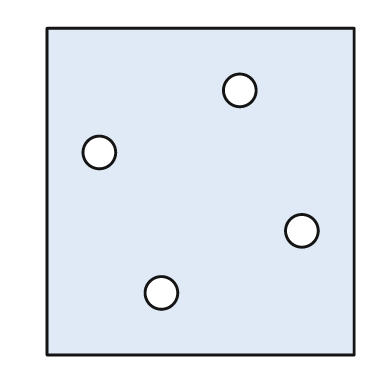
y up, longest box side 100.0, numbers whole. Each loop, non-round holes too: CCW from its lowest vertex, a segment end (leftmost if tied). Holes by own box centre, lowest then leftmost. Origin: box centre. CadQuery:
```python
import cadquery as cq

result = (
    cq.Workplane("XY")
    .moveTo(-47.0, -50.0)
    .lineTo(47.0, -50.0)
    .lineTo(47.0, 50.0)
    .lineTo(-47.0, 50.0)
    .close()
    .moveTo(-12.0, -31.0)
    .circle(5.0)
    .moveTo(31.0, -12.0)
    .circle(5.0)
    .moveTo(-31.0, 12.0)
    .circle(5.0)
    .moveTo(12.0, 31.0)
    .circle(5.0)
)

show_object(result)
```